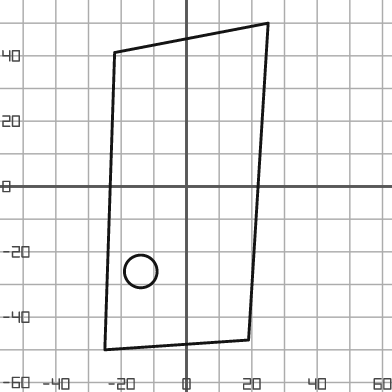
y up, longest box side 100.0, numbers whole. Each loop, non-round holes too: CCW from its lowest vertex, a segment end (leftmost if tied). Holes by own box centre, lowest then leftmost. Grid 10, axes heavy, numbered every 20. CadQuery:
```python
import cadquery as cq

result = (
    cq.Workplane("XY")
    .moveTo(-25.0, -50.0)
    .lineTo(19.0, -47.0)
    .lineTo(25.0, 50.0)
    .lineTo(-22.0, 41.0)
    .close()
    .moveTo(-14.0, -26.0)
    .circle(5.0)
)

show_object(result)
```